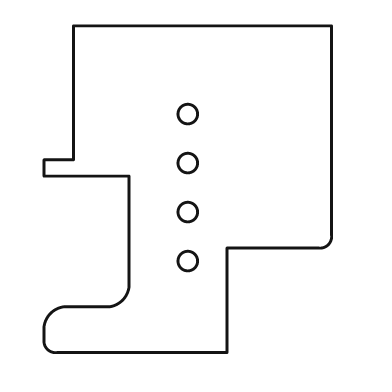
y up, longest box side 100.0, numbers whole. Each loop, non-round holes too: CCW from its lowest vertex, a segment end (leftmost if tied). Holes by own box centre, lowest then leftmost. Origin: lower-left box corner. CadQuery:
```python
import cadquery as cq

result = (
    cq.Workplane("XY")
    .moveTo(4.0, 0.0)
    .lineTo(56.0, 0.0)
    .lineTo(56.0, 32.0)
    .lineTo(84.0, 32.0)
    .threePointArc((87.0, 33.0), (88.0, 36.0))
    .lineTo(88.0, 100.0)
    .lineTo(9.0, 100.0)
    .lineTo(9.0, 59.0)
    .lineTo(0.0, 59.0)
    .lineTo(0.0, 54.0)
    .lineTo(26.0, 54.0)
    .lineTo(26.0, 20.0)
    .threePointArc((24.0, 16.0), (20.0, 14.0))
    .lineTo(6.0, 14.0)
    .threePointArc((2.0, 12.0), (0.0, 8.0))
    .lineTo(0.0, 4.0)
    .threePointArc((1.0, 1.0), (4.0, 0.0))
    .close()
    .moveTo(44.0, 28.0)
    .circle(3.0)
    .moveTo(44.0, 43.0)
    .circle(3.0)
    .moveTo(44.0, 58.0)
    .circle(3.0)
    .moveTo(44.0, 73.0)
    .circle(3.0)
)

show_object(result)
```